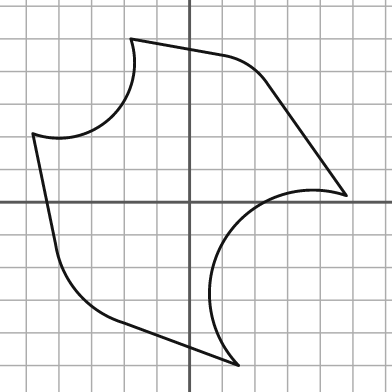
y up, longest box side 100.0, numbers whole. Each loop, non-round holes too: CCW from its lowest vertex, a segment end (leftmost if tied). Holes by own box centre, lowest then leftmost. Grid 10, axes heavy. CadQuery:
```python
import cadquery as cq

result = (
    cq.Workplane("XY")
    .moveTo(15.0, -50.0)
    .threePointArc((11.0, -11.0), (48.0, 2.0))
    .lineTo(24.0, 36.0)
    .threePointArc((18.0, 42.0), (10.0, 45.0))
    .lineTo(-18.0, 50.0)
    .threePointArc((-24.0, 26.0), (-48.0, 21.0))
    .lineTo(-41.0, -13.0)
    .threePointArc((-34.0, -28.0), (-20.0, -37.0))
    .close()
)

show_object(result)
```